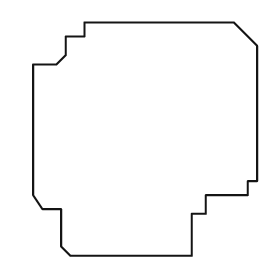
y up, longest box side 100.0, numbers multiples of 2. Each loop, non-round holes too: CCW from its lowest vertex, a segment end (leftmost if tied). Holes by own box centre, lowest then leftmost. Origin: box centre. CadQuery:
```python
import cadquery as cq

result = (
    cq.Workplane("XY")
    .moveTo(-32.0, -50.0)
    .lineTo(20.0, -50.0)
    .lineTo(20.0, -32.0)
    .lineTo(26.0, -32.0)
    .lineTo(26.0, -24.0)
    .lineTo(44.0, -24.0)
    .lineTo(44.0, -18.0)
    .lineTo(48.0, -18.0)
    .lineTo(48.0, 40.0)
    .lineTo(38.0, 50.0)
    .lineTo(-26.0, 50.0)
    .lineTo(-26.0, 44.0)
    .lineTo(-34.0, 44.0)
    .lineTo(-34.0, 36.0)
    .lineTo(-38.0, 32.0)
    .lineTo(-48.0, 32.0)
    .lineTo(-48.0, -24.0)
    .lineTo(-44.0, -30.0)
    .lineTo(-36.0, -30.0)
    .lineTo(-36.0, -46.0)
    .close()
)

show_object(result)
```